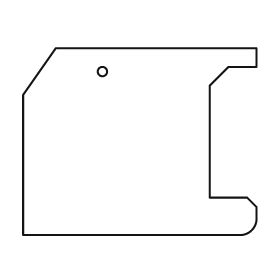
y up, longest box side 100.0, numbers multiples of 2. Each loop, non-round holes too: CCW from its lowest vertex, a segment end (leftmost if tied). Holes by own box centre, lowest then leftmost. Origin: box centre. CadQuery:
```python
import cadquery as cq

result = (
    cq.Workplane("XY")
    .moveTo(-50.0, -40.0)
    .lineTo(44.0, -40.0)
    .threePointArc((48.0, -38.0), (50.0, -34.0))
    .lineTo(50.0, -28.0)
    .lineTo(46.0, -24.0)
    .lineTo(30.0, -24.0)
    .lineTo(30.0, 24.0)
    .lineTo(38.0, 32.0)
    .lineTo(50.0, 32.0)
    .lineTo(50.0, 40.0)
    .lineTo(-36.0, 40.0)
    .lineTo(-50.0, 20.0)
    .close()
    .moveTo(-16.0, 30.0)
    .circle(2.0)
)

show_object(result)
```